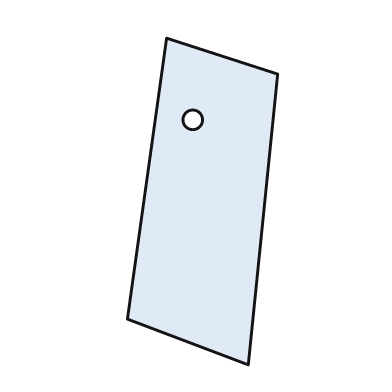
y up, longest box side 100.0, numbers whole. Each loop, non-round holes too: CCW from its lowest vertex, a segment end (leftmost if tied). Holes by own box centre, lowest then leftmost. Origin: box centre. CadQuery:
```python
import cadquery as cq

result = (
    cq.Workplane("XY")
    .moveTo(14.0, -50.0)
    .lineTo(23.0, 39.0)
    .lineTo(-11.0, 50.0)
    .lineTo(-23.0, -36.0)
    .close()
    .moveTo(-3.0, 25.0)
    .circle(3.0)
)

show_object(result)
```